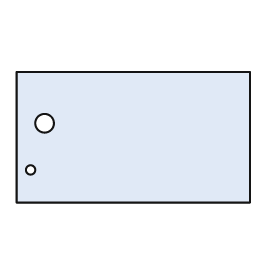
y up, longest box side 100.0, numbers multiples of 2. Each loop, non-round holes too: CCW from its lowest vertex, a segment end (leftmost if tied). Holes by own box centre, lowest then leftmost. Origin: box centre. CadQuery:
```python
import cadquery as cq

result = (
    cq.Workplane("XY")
    .moveTo(-50.0, -28.0)
    .lineTo(50.0, -28.0)
    .lineTo(50.0, 28.0)
    .lineTo(-50.0, 28.0)
    .close()
    .moveTo(-44.0, -14.0)
    .circle(2.0)
    .moveTo(-38.0, 6.0)
    .circle(4.0)
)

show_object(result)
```